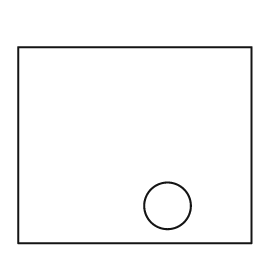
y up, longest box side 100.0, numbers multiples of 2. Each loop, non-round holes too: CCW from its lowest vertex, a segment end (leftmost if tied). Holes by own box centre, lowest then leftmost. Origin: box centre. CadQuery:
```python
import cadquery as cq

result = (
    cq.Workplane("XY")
    .moveTo(-50.0, -42.0)
    .lineTo(50.0, -42.0)
    .lineTo(50.0, 42.0)
    .lineTo(-50.0, 42.0)
    .close()
    .moveTo(14.0, -26.0)
    .circle(10.0)
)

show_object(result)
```